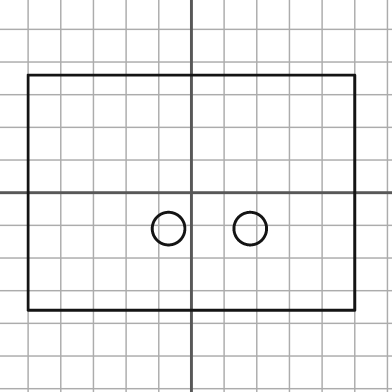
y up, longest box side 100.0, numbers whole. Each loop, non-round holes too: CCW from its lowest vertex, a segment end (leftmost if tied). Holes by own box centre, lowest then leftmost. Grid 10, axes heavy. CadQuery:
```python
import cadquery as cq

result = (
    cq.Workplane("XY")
    .moveTo(-50.0, -36.0)
    .lineTo(50.0, -36.0)
    .lineTo(50.0, 36.0)
    .lineTo(-50.0, 36.0)
    .close()
    .moveTo(-7.0, -11.0)
    .circle(5.0)
    .moveTo(18.0, -11.0)
    .circle(5.0)
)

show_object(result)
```